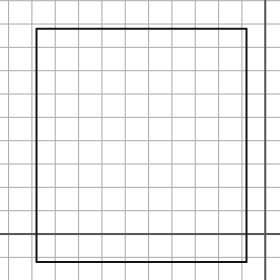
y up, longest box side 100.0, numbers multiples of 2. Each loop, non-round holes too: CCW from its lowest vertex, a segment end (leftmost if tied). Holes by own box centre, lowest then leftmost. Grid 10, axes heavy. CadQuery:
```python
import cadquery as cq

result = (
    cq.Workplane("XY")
    .moveTo(-98.0, -12.0)
    .lineTo(-8.0, -12.0)
    .lineTo(-8.0, 88.0)
    .lineTo(-98.0, 88.0)
    .close()
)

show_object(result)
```